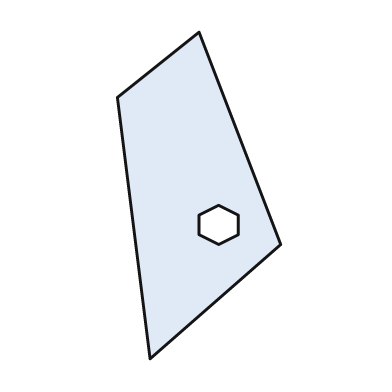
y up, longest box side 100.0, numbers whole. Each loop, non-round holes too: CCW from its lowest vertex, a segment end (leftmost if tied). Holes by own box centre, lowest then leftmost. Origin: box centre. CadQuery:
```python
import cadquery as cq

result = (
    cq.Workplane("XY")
    .moveTo(-15.0, -50.0)
    .lineTo(25.0, -15.0)
    .lineTo(0.0, 50.0)
    .lineTo(-25.0, 30.0)
    .close()
    .moveTo(6.0, -15.0)
    .lineTo(12.0, -12.0)
    .lineTo(12.0, -6.0)
    .lineTo(6.0, -3.0)
    .lineTo(0.0, -6.0)
    .lineTo(0.0, -12.0)
    .close()
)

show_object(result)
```